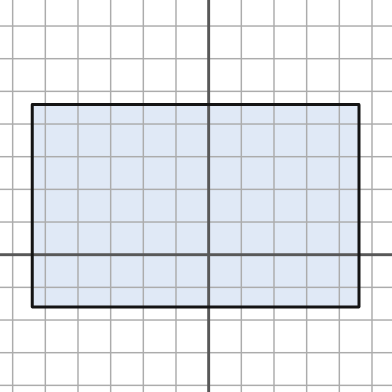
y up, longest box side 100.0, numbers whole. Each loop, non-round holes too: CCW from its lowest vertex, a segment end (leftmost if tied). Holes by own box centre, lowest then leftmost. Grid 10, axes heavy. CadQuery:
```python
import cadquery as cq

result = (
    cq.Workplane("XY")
    .moveTo(-54.0, -16.0)
    .lineTo(46.0, -16.0)
    .lineTo(46.0, 46.0)
    .lineTo(-54.0, 46.0)
    .close()
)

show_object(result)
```